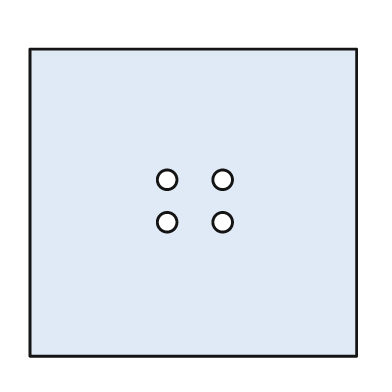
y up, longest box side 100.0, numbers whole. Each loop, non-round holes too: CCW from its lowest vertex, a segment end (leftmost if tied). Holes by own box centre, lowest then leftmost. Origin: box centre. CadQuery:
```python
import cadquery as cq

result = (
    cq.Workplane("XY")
    .moveTo(-50.0, -47.0)
    .lineTo(50.0, -47.0)
    .lineTo(50.0, 47.0)
    .lineTo(-50.0, 47.0)
    .close()
    .moveTo(-8.0, -6.0)
    .circle(3.0)
    .moveTo(9.0, -6.0)
    .circle(3.0)
    .moveTo(-8.0, 7.0)
    .circle(3.0)
    .moveTo(9.0, 7.0)
    .circle(3.0)
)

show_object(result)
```